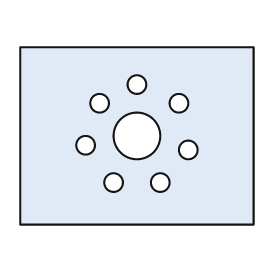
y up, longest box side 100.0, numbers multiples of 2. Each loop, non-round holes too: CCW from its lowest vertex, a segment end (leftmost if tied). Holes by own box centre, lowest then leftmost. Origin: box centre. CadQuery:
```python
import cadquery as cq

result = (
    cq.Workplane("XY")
    .moveTo(-50.0, -38.0)
    .lineTo(50.0, -38.0)
    .lineTo(50.0, 38.0)
    .lineTo(-50.0, 38.0)
    .close()
    .moveTo(-10.0, -20.0)
    .circle(4.0)
    .moveTo(10.0, -20.0)
    .circle(4.0)
    .moveTo(22.0, -6.0)
    .circle(4.0)
    .moveTo(-22.0, -4.0)
    .circle(4.0)
    .moveTo(0.0, 0.0)
    .circle(10.0)
    .moveTo(-16.0, 14.0)
    .circle(4.0)
    .moveTo(18.0, 14.0)
    .circle(4.0)
    .moveTo(0.0, 22.0)
    .circle(4.0)
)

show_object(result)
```